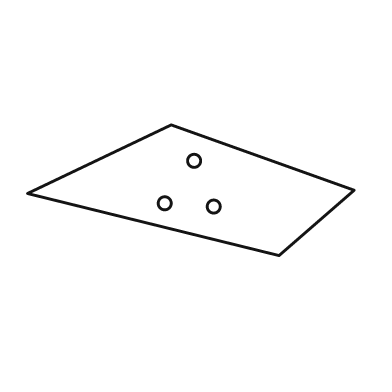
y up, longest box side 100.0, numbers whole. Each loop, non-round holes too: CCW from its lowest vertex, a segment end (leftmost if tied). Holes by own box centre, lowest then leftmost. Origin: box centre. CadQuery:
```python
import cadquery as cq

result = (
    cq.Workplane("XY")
    .moveTo(27.0, -20.0)
    .lineTo(50.0, 0.0)
    .lineTo(-6.0, 20.0)
    .lineTo(-50.0, -1.0)
    .close()
    .moveTo(7.0, -5.0)
    .circle(2.0)
    .moveTo(-8.0, -4.0)
    .circle(2.0)
    .moveTo(1.0, 9.0)
    .circle(2.0)
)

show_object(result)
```